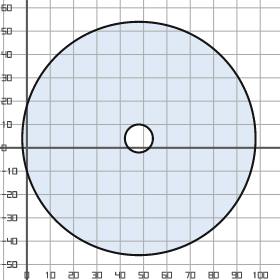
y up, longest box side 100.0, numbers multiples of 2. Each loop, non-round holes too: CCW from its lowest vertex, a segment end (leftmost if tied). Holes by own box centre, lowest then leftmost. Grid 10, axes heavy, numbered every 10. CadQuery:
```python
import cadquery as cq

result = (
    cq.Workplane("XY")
    .moveTo(48.0, 4.0)
    .circle(50.0)
    .moveTo(48.0, 4.0)
    .circle(6.0)
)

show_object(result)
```